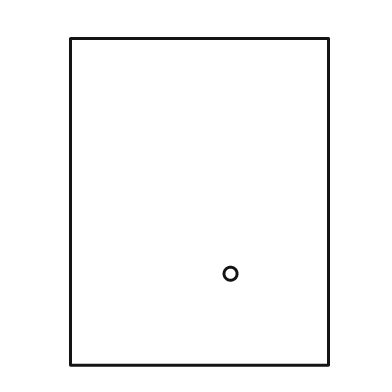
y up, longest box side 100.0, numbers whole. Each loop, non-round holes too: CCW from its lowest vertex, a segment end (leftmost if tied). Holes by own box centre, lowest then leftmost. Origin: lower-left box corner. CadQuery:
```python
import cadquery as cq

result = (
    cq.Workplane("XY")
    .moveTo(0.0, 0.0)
    .lineTo(79.0, 0.0)
    .lineTo(79.0, 100.0)
    .lineTo(0.0, 100.0)
    .close()
    .moveTo(49.0, 28.0)
    .circle(2.0)
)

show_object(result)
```